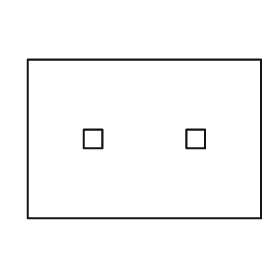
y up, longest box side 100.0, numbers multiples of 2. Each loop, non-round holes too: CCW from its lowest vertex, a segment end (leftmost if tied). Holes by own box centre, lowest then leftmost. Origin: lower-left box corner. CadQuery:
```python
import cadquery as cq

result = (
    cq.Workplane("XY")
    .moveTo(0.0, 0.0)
    .lineTo(100.0, 0.0)
    .lineTo(100.0, 68.0)
    .lineTo(0.0, 68.0)
    .close()
    .moveTo(24.0, 30.0)
    .lineTo(32.0, 30.0)
    .lineTo(32.0, 38.0)
    .lineTo(24.0, 38.0)
    .close()
    .moveTo(68.0, 30.0)
    .lineTo(76.0, 30.0)
    .lineTo(76.0, 38.0)
    .lineTo(68.0, 38.0)
    .close()
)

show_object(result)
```